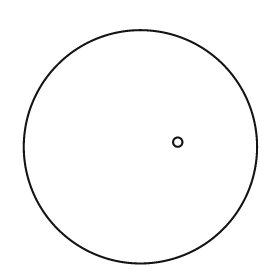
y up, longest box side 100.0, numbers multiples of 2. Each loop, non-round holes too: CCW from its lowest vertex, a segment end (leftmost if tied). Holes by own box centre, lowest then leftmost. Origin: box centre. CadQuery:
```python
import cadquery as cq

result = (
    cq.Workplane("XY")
    .moveTo(0.0, 0.0)
    .circle(50.0)
    .moveTo(16.0, 2.0)
    .circle(2.0)
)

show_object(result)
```